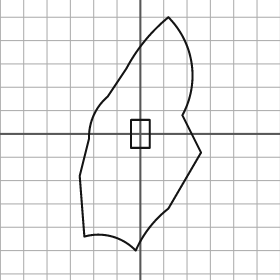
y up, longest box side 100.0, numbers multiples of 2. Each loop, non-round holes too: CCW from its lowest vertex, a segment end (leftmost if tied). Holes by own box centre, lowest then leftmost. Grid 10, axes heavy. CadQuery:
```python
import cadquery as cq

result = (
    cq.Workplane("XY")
    .moveTo(-2.0, -50.0)
    .threePointArc((4.0, -40.0), (12.0, -32.0))
    .lineTo(26.0, -8.0)
    .lineTo(18.0, 8.0)
    .threePointArc((22.0, 30.0), (12.0, 50.0))
    .threePointArc((2.0, 40.0), (-6.0, 28.0))
    .lineTo(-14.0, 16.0)
    .threePointArc((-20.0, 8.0), (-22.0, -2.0))
    .lineTo(-26.0, -18.0)
    .lineTo(-24.0, -44.0)
    .threePointArc((-12.0, -44.0), (-2.0, -50.0))
    .close()
    .moveTo(-4.0, -6.0)
    .lineTo(4.0, -6.0)
    .lineTo(4.0, 6.0)
    .lineTo(-4.0, 6.0)
    .close()
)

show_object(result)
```